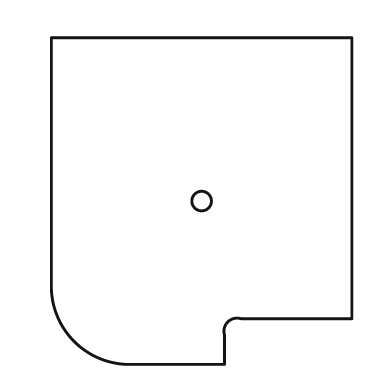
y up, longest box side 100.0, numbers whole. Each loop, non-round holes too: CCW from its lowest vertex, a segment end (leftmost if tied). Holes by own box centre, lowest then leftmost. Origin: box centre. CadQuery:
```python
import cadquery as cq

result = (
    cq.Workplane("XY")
    .moveTo(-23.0, -50.0)
    .lineTo(7.0, -50.0)
    .lineTo(7.0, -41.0)
    .threePointArc((8.0, -37.0), (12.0, -36.0))
    .lineTo(46.0, -36.0)
    .lineTo(46.0, 50.0)
    .lineTo(-46.0, 50.0)
    .lineTo(-46.0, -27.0)
    .threePointArc((-39.0, -43.0), (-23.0, -50.0))
    .close()
    .moveTo(0.0, 0.0)
    .circle(3.0)
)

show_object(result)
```